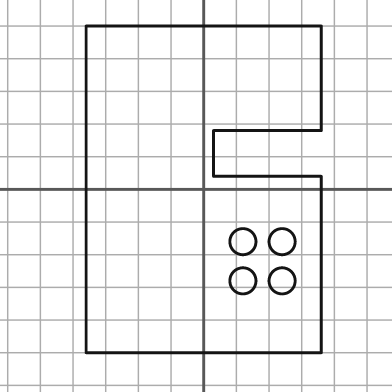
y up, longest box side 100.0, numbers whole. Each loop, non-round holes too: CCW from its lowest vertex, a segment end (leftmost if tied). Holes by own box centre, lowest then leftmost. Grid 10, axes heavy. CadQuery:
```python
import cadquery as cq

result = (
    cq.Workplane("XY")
    .moveTo(-36.0, -50.0)
    .lineTo(36.0, -50.0)
    .lineTo(36.0, 4.0)
    .lineTo(3.0, 4.0)
    .lineTo(3.0, 18.0)
    .lineTo(36.0, 18.0)
    .lineTo(36.0, 50.0)
    .lineTo(-36.0, 50.0)
    .close()
    .moveTo(12.0, -28.0)
    .circle(4.0)
    .moveTo(24.0, -28.0)
    .circle(4.0)
    .moveTo(12.0, -16.0)
    .circle(4.0)
    .moveTo(24.0, -16.0)
    .circle(4.0)
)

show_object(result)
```